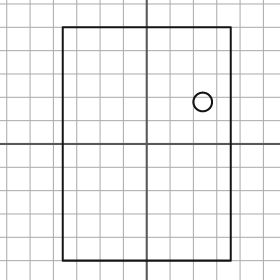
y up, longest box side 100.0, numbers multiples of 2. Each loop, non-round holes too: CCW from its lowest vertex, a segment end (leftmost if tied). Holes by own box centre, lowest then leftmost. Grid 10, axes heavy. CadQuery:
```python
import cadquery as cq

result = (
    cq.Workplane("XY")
    .moveTo(-36.0, -50.0)
    .lineTo(36.0, -50.0)
    .lineTo(36.0, 50.0)
    .lineTo(-36.0, 50.0)
    .close()
    .moveTo(24.0, 18.0)
    .circle(4.0)
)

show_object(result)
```